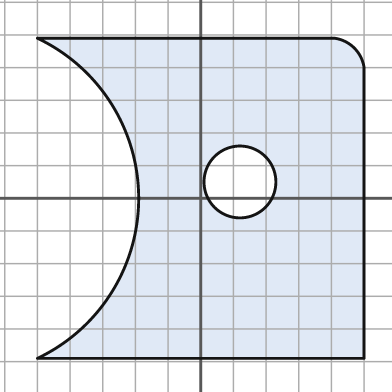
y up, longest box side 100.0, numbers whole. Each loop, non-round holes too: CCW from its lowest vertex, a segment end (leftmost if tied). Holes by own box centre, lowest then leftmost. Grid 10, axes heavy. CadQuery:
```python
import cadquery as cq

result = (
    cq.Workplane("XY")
    .moveTo(-50.0, -49.0)
    .lineTo(50.0, -49.0)
    .lineTo(50.0, 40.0)
    .threePointArc((47.0, 46.0), (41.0, 49.0))
    .lineTo(-50.0, 49.0)
    .threePointArc((-19.0, 0.0), (-50.0, -49.0))
    .close()
    .moveTo(12.0, 5.0)
    .circle(11.0)
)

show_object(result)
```